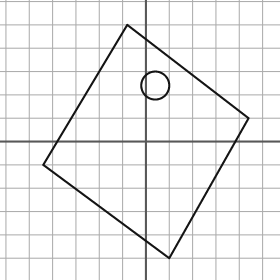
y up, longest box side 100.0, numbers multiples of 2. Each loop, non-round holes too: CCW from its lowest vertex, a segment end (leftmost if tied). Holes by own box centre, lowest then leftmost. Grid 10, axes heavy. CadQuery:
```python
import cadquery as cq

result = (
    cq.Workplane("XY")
    .moveTo(10.0, -50.0)
    .lineTo(44.0, 10.0)
    .lineTo(-8.0, 50.0)
    .lineTo(-44.0, -10.0)
    .close()
    .moveTo(4.0, 24.0)
    .circle(6.0)
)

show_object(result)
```